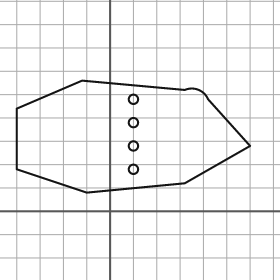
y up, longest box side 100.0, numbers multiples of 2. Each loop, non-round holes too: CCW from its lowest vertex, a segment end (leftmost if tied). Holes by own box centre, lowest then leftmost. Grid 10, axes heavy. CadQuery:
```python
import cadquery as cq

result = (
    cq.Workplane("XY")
    .moveTo(-10.0, 8.0)
    .lineTo(32.0, 12.0)
    .lineTo(60.0, 28.0)
    .lineTo(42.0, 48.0)
    .threePointArc((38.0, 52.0), (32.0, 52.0))
    .lineTo(-12.0, 56.0)
    .lineTo(-40.0, 44.0)
    .lineTo(-40.0, 18.0)
    .close()
    .moveTo(10.0, 18.0)
    .circle(2.0)
    .moveTo(10.0, 28.0)
    .circle(2.0)
    .moveTo(10.0, 38.0)
    .circle(2.0)
    .moveTo(10.0, 48.0)
    .circle(2.0)
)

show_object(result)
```